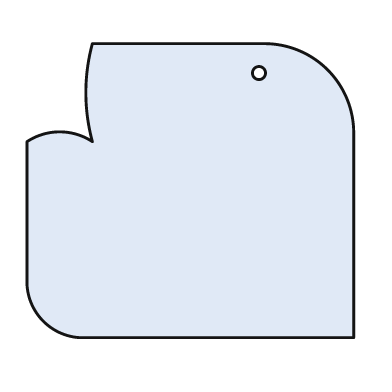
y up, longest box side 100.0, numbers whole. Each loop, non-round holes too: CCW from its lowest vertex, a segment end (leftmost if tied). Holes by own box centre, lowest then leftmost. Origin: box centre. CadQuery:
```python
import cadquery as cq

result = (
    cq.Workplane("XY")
    .moveTo(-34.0, -45.0)
    .lineTo(50.0, -45.0)
    .lineTo(50.0, 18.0)
    .threePointArc((42.0, 37.0), (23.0, 45.0))
    .lineTo(-30.0, 45.0)
    .threePointArc((-32.0, 30.0), (-30.0, 15.0))
    .threePointArc((-40.0, 18.0), (-50.0, 15.0))
    .lineTo(-50.0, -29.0)
    .threePointArc((-45.0, -40.0), (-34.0, -45.0))
    .close()
    .moveTo(21.0, 36.0)
    .circle(2.0)
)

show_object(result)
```